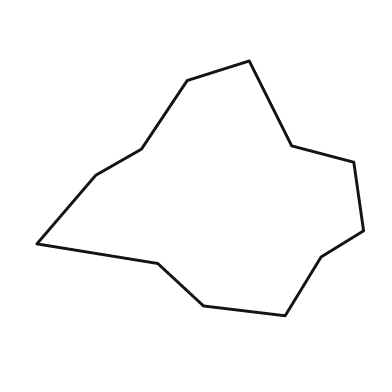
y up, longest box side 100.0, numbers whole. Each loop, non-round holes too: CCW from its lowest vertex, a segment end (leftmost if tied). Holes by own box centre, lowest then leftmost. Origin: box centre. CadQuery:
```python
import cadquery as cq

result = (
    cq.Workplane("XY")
    .moveTo(26.0, -39.0)
    .lineTo(37.0, -21.0)
    .lineTo(50.0, -13.0)
    .lineTo(47.0, 8.0)
    .lineTo(28.0, 13.0)
    .lineTo(15.0, 39.0)
    .lineTo(-4.0, 33.0)
    .lineTo(-18.0, 12.0)
    .lineTo(-32.0, 4.0)
    .lineTo(-50.0, -17.0)
    .lineTo(-13.0, -23.0)
    .lineTo(1.0, -36.0)
    .close()
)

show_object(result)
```